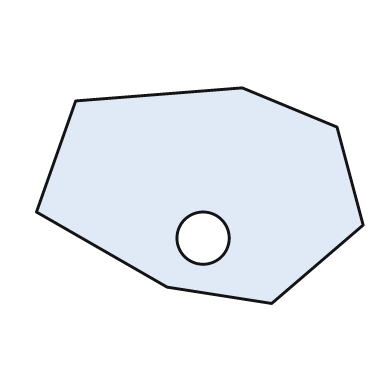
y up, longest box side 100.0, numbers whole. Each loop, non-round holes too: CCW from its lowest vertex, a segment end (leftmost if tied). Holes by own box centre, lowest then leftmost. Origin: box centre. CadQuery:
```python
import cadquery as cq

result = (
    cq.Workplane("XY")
    .moveTo(22.0, -33.0)
    .lineTo(50.0, -9.0)
    .lineTo(42.0, 21.0)
    .lineTo(13.0, 33.0)
    .lineTo(-38.0, 29.0)
    .lineTo(-50.0, -5.0)
    .lineTo(-10.0, -28.0)
    .close()
    .moveTo(1.0, -13.0)
    .circle(8.0)
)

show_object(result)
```